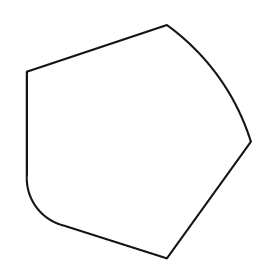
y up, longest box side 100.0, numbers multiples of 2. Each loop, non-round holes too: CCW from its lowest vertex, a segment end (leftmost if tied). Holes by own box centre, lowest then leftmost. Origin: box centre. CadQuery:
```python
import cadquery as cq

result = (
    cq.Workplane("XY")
    .moveTo(12.0, -50.0)
    .lineTo(48.0, 0.0)
    .threePointArc((34.0, 28.0), (12.0, 50.0))
    .lineTo(-48.0, 30.0)
    .lineTo(-48.0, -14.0)
    .threePointArc((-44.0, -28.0), (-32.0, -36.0))
    .close()
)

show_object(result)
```